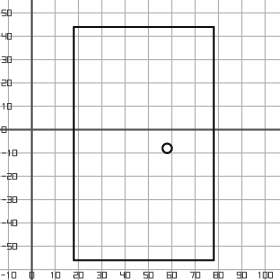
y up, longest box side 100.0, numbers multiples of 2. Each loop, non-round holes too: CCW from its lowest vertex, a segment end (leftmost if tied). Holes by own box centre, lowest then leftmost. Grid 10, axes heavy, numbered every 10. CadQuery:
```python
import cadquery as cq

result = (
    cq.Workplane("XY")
    .moveTo(18.0, -56.0)
    .lineTo(78.0, -56.0)
    .lineTo(78.0, 44.0)
    .lineTo(18.0, 44.0)
    .close()
    .moveTo(58.0, -8.0)
    .circle(2.0)
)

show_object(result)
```